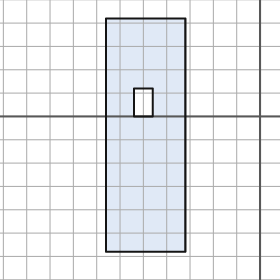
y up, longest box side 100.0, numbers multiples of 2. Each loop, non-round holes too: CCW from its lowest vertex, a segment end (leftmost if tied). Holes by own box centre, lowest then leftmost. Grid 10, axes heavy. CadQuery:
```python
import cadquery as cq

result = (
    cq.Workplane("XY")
    .moveTo(-66.0, -58.0)
    .lineTo(-32.0, -58.0)
    .lineTo(-32.0, 42.0)
    .lineTo(-66.0, 42.0)
    .close()
    .moveTo(-54.0, 0.0)
    .lineTo(-46.0, 0.0)
    .lineTo(-46.0, 12.0)
    .lineTo(-54.0, 12.0)
    .close()
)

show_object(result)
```